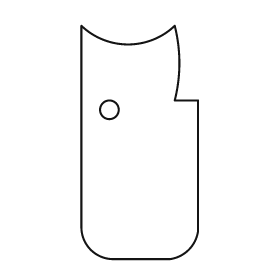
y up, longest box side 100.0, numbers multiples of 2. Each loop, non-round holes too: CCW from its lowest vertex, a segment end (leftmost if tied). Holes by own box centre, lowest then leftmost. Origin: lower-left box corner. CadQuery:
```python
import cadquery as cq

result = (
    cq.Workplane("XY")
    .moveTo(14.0, 0.0)
    .lineTo(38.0, 0.0)
    .threePointArc((46.0, 4.0), (50.0, 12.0))
    .lineTo(50.0, 68.0)
    .lineTo(40.0, 68.0)
    .threePointArc((42.0, 84.0), (40.0, 100.0))
    .threePointArc((20.0, 92.0), (0.0, 100.0))
    .lineTo(0.0, 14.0)
    .threePointArc((4.0, 4.0), (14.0, 0.0))
    .close()
    .moveTo(12.0, 64.0)
    .circle(4.0)
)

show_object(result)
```